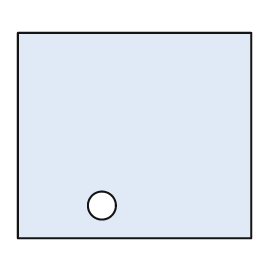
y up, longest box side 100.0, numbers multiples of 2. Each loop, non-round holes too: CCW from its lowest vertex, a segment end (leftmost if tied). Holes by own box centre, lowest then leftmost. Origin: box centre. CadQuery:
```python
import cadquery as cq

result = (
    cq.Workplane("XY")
    .moveTo(-50.0, -44.0)
    .lineTo(50.0, -44.0)
    .lineTo(50.0, 44.0)
    .lineTo(-50.0, 44.0)
    .close()
    .moveTo(-14.0, -30.0)
    .circle(6.0)
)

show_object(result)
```